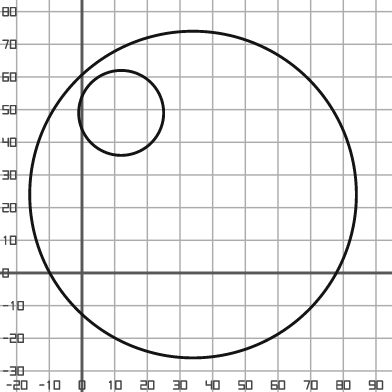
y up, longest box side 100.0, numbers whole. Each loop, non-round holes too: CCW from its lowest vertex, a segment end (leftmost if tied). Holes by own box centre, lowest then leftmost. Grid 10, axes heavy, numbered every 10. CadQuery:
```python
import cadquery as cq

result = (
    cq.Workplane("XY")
    .moveTo(34.0, 24.0)
    .circle(50.0)
    .moveTo(12.0, 49.0)
    .circle(13.0)
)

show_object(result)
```